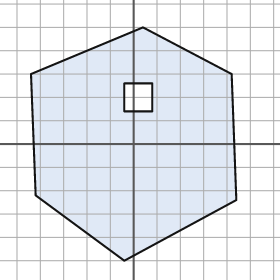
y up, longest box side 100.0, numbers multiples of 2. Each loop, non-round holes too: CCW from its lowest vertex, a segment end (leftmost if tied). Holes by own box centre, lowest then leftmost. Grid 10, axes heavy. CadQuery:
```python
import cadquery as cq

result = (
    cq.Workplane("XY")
    .moveTo(-4.0, -50.0)
    .lineTo(44.0, -24.0)
    .lineTo(42.0, 30.0)
    .lineTo(4.0, 50.0)
    .lineTo(-44.0, 30.0)
    .lineTo(-42.0, -22.0)
    .close()
    .moveTo(-4.0, 14.0)
    .lineTo(8.0, 14.0)
    .lineTo(8.0, 26.0)
    .lineTo(-4.0, 26.0)
    .close()
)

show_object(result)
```